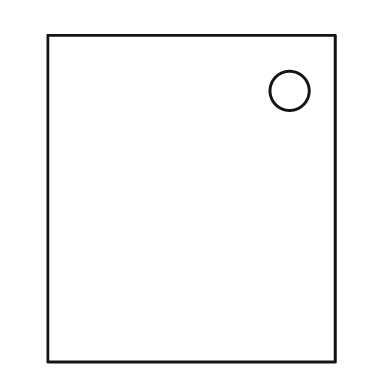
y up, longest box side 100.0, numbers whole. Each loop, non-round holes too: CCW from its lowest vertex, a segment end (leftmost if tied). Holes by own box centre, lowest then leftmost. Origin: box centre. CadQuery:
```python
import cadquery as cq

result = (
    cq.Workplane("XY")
    .moveTo(-44.0, -50.0)
    .lineTo(44.0, -50.0)
    .lineTo(44.0, 50.0)
    .lineTo(-44.0, 50.0)
    .close()
    .moveTo(30.0, 33.0)
    .circle(6.0)
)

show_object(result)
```